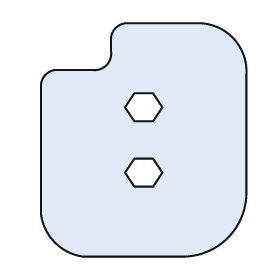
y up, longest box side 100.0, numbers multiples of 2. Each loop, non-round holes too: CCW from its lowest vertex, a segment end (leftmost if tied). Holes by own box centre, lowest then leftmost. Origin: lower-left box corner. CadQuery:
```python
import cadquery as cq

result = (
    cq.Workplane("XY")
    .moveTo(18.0, 0.0)
    .lineTo(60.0, 0.0)
    .threePointArc((80.0, 8.0), (88.0, 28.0))
    .lineTo(88.0, 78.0)
    .threePointArc((82.0, 94.0), (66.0, 100.0))
    .lineTo(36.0, 100.0)
    .threePointArc((32.0, 98.0), (30.0, 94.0))
    .lineTo(30.0, 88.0)
    .threePointArc((28.0, 82.0), (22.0, 80.0))
    .lineTo(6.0, 80.0)
    .threePointArc((2.0, 78.0), (0.0, 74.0))
    .lineTo(0.0, 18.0)
    .threePointArc((6.0, 6.0), (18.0, 0.0))
    .close()
    .moveTo(40.0, 30.0)
    .lineTo(48.0, 30.0)
    .lineTo(52.0, 36.0)
    .lineTo(48.0, 42.0)
    .lineTo(40.0, 42.0)
    .lineTo(36.0, 36.0)
    .close()
    .moveTo(40.0, 58.0)
    .lineTo(48.0, 58.0)
    .lineTo(52.0, 64.0)
    .lineTo(48.0, 70.0)
    .lineTo(40.0, 70.0)
    .lineTo(36.0, 64.0)
    .close()
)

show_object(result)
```